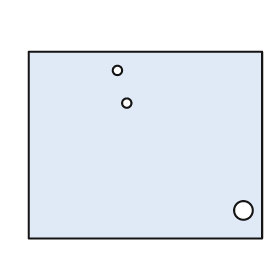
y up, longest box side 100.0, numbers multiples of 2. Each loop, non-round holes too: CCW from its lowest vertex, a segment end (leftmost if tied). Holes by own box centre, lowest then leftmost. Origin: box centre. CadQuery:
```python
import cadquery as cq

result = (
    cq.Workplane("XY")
    .moveTo(-50.0, -40.0)
    .lineTo(50.0, -40.0)
    .lineTo(50.0, 40.0)
    .lineTo(-50.0, 40.0)
    .close()
    .moveTo(42.0, -28.0)
    .circle(4.0)
    .moveTo(-8.0, 18.0)
    .circle(2.0)
    .moveTo(-12.0, 32.0)
    .circle(2.0)
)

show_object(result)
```